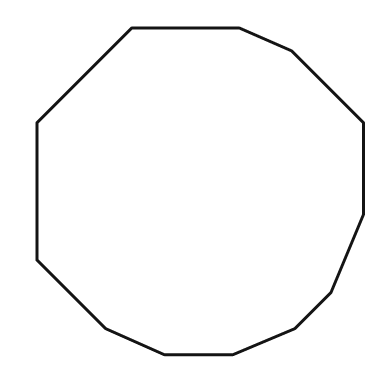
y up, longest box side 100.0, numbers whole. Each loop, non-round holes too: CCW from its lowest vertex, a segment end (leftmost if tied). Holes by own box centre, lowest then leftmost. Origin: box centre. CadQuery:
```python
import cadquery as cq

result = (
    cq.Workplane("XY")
    .moveTo(-11.0, -50.0)
    .lineTo(10.0, -50.0)
    .lineTo(29.0, -42.0)
    .lineTo(40.0, -31.0)
    .lineTo(50.0, -7.0)
    .lineTo(50.0, 21.0)
    .lineTo(28.0, 43.0)
    .lineTo(12.0, 50.0)
    .lineTo(-21.0, 50.0)
    .lineTo(-50.0, 21.0)
    .lineTo(-50.0, -21.0)
    .lineTo(-29.0, -42.0)
    .close()
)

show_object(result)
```